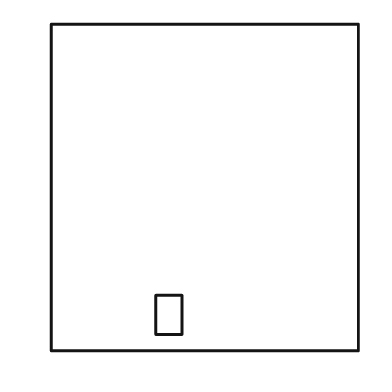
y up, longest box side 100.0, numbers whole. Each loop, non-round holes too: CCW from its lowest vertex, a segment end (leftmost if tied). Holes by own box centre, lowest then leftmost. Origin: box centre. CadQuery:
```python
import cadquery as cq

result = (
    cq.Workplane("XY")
    .moveTo(-47.0, -50.0)
    .lineTo(47.0, -50.0)
    .lineTo(47.0, 50.0)
    .lineTo(-47.0, 50.0)
    .close()
    .moveTo(-15.0, -45.0)
    .lineTo(-7.0, -45.0)
    .lineTo(-7.0, -33.0)
    .lineTo(-15.0, -33.0)
    .close()
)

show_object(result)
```